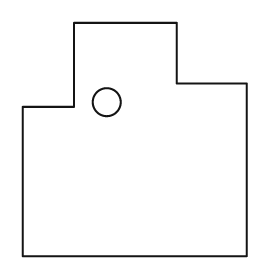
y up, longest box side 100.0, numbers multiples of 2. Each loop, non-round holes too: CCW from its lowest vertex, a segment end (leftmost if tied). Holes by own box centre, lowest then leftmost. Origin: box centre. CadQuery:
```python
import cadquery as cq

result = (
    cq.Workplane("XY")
    .moveTo(-48.0, -50.0)
    .lineTo(48.0, -50.0)
    .lineTo(48.0, 24.0)
    .lineTo(18.0, 24.0)
    .lineTo(18.0, 50.0)
    .lineTo(-26.0, 50.0)
    .lineTo(-26.0, 14.0)
    .lineTo(-48.0, 14.0)
    .close()
    .moveTo(-12.0, 16.0)
    .circle(6.0)
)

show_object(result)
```